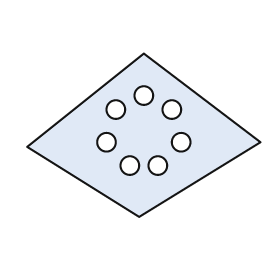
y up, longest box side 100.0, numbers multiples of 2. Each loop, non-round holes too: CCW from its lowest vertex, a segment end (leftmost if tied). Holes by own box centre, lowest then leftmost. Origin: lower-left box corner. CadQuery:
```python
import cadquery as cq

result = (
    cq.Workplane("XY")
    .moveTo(48.0, 0.0)
    .lineTo(100.0, 32.0)
    .lineTo(50.0, 70.0)
    .lineTo(0.0, 30.0)
    .close()
    .moveTo(44.0, 22.0)
    .circle(4.0)
    .moveTo(56.0, 22.0)
    .circle(4.0)
    .moveTo(34.0, 32.0)
    .circle(4.0)
    .moveTo(66.0, 32.0)
    .circle(4.0)
    .moveTo(38.0, 46.0)
    .circle(4.0)
    .moveTo(62.0, 46.0)
    .circle(4.0)
    .moveTo(50.0, 52.0)
    .circle(4.0)
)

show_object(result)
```